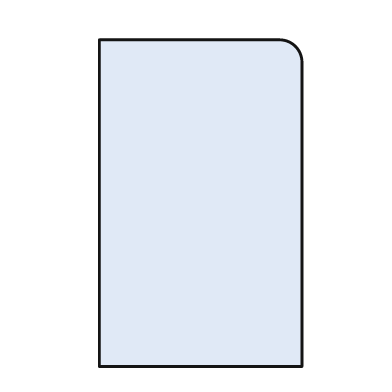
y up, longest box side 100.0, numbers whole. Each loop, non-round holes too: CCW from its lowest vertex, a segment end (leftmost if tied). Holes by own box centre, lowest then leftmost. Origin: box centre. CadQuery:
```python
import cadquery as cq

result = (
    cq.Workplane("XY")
    .moveTo(-31.0, -50.0)
    .lineTo(31.0, -50.0)
    .lineTo(31.0, 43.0)
    .threePointArc((29.0, 48.0), (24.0, 50.0))
    .lineTo(-31.0, 50.0)
    .close()
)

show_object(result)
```